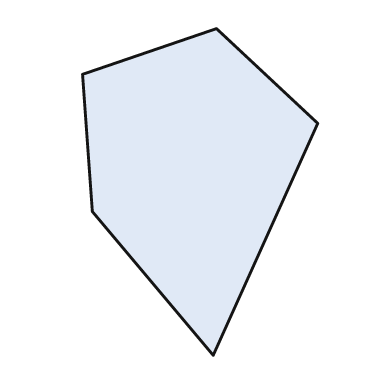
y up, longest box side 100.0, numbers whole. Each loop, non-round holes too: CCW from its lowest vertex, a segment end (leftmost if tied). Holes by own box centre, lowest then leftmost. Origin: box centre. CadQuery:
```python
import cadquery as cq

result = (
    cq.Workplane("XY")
    .moveTo(4.0, -50.0)
    .lineTo(36.0, 21.0)
    .lineTo(5.0, 50.0)
    .lineTo(-36.0, 36.0)
    .lineTo(-33.0, -6.0)
    .close()
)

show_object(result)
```